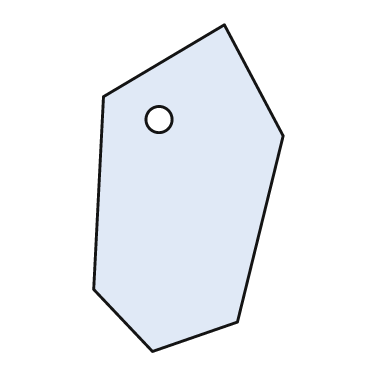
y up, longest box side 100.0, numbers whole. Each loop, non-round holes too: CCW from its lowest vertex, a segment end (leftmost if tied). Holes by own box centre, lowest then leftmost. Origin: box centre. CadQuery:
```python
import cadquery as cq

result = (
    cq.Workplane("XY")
    .moveTo(-11.0, -50.0)
    .lineTo(15.0, -41.0)
    .lineTo(29.0, 16.0)
    .lineTo(11.0, 50.0)
    .lineTo(-26.0, 28.0)
    .lineTo(-29.0, -31.0)
    .close()
    .moveTo(-9.0, 21.0)
    .circle(4.0)
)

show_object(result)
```